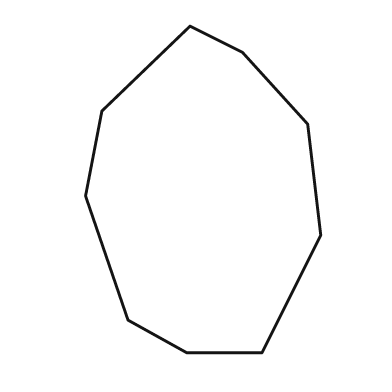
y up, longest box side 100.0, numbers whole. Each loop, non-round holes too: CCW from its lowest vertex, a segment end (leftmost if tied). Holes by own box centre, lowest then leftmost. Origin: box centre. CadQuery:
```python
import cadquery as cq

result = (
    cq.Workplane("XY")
    .moveTo(-5.0, -50.0)
    .lineTo(18.0, -50.0)
    .lineTo(36.0, -14.0)
    .lineTo(32.0, 20.0)
    .lineTo(12.0, 42.0)
    .lineTo(-4.0, 50.0)
    .lineTo(-31.0, 24.0)
    .lineTo(-36.0, -2.0)
    .lineTo(-23.0, -40.0)
    .close()
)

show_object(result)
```